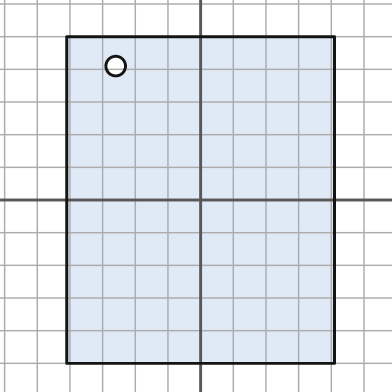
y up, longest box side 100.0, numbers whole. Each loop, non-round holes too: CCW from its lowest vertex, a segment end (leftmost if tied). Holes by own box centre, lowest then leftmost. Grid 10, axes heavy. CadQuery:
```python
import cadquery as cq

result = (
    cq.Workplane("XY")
    .moveTo(-41.0, -50.0)
    .lineTo(41.0, -50.0)
    .lineTo(41.0, 50.0)
    .lineTo(-41.0, 50.0)
    .close()
    .moveTo(-26.0, 41.0)
    .circle(3.0)
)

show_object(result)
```